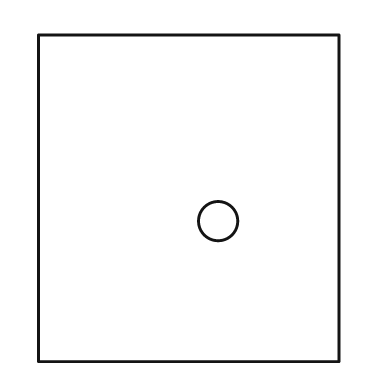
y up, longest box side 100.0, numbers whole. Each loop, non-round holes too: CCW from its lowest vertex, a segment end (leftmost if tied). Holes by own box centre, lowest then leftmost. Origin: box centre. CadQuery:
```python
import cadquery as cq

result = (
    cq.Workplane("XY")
    .moveTo(-46.0, -50.0)
    .lineTo(46.0, -50.0)
    .lineTo(46.0, 50.0)
    .lineTo(-46.0, 50.0)
    .close()
    .moveTo(9.0, -7.0)
    .circle(6.0)
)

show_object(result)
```